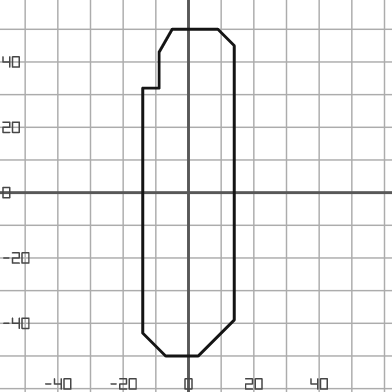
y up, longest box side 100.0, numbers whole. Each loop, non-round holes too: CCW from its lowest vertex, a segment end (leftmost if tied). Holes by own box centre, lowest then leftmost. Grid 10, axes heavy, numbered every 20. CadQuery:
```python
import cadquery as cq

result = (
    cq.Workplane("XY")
    .moveTo(-7.0, -50.0)
    .lineTo(3.0, -50.0)
    .lineTo(14.0, -39.0)
    .lineTo(14.0, 45.0)
    .lineTo(9.0, 50.0)
    .lineTo(-5.0, 50.0)
    .lineTo(-9.0, 43.0)
    .lineTo(-9.0, 32.0)
    .lineTo(-14.0, 32.0)
    .lineTo(-14.0, -43.0)
    .close()
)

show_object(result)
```